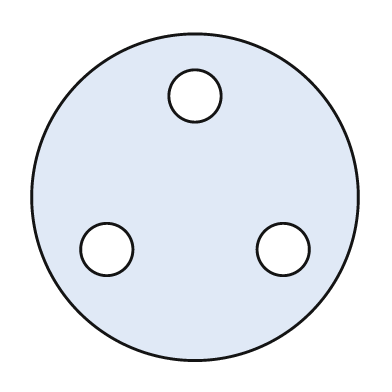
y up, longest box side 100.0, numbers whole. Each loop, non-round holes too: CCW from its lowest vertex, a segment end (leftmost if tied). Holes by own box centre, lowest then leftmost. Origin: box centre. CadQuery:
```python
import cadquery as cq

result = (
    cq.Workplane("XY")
    .moveTo(0.0, 0.0)
    .circle(50.0)
    .moveTo(-27.0, -16.0)
    .circle(8.0)
    .moveTo(27.0, -16.0)
    .circle(8.0)
    .moveTo(0.0, 31.0)
    .circle(8.0)
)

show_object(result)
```